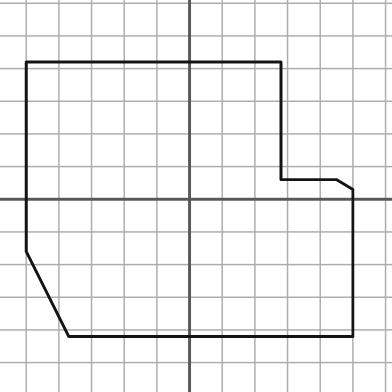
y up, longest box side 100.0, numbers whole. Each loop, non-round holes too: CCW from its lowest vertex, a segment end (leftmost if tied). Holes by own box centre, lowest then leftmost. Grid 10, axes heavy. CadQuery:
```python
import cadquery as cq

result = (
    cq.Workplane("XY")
    .moveTo(-37.0, -42.0)
    .lineTo(50.0, -42.0)
    .lineTo(50.0, 3.0)
    .lineTo(45.0, 6.0)
    .lineTo(28.0, 6.0)
    .lineTo(28.0, 42.0)
    .lineTo(-50.0, 42.0)
    .lineTo(-50.0, -16.0)
    .close()
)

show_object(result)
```